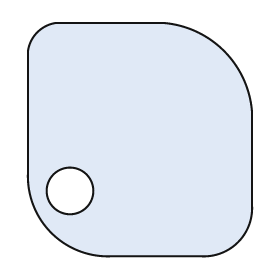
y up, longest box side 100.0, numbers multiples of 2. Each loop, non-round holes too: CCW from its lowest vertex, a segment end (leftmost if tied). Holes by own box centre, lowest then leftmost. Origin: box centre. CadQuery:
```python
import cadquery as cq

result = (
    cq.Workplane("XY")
    .moveTo(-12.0, -50.0)
    .lineTo(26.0, -50.0)
    .threePointArc((42.0, -44.0), (48.0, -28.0))
    .lineTo(48.0, 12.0)
    .threePointArc((36.0, 38.0), (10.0, 50.0))
    .lineTo(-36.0, 50.0)
    .threePointArc((-44.0, 46.0), (-48.0, 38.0))
    .lineTo(-48.0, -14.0)
    .threePointArc((-38.0, -40.0), (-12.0, -50.0))
    .close()
    .moveTo(-30.0, -22.0)
    .circle(10.0)
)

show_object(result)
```